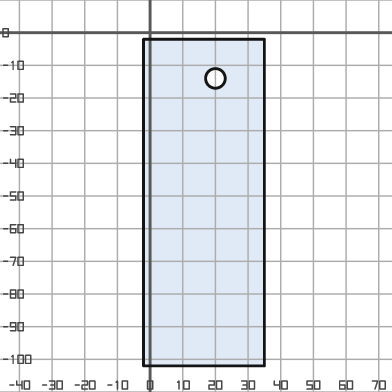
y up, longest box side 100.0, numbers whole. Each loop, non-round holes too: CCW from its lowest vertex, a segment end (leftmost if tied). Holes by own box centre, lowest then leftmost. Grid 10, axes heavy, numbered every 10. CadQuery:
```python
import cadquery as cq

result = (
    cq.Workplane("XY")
    .moveTo(-2.0, -102.0)
    .lineTo(35.0, -102.0)
    .lineTo(35.0, -2.0)
    .lineTo(-2.0, -2.0)
    .close()
    .moveTo(20.0, -14.0)
    .circle(3.0)
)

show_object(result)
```